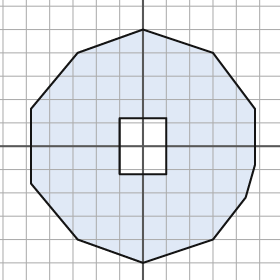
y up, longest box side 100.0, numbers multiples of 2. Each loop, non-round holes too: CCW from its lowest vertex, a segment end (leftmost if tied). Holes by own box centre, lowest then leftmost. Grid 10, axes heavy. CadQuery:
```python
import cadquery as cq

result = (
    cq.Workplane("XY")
    .moveTo(0.0, -50.0)
    .lineTo(30.0, -40.0)
    .lineTo(44.0, -22.0)
    .lineTo(48.0, -8.0)
    .lineTo(48.0, 16.0)
    .lineTo(30.0, 40.0)
    .lineTo(0.0, 50.0)
    .lineTo(-28.0, 40.0)
    .lineTo(-48.0, 16.0)
    .lineTo(-48.0, -16.0)
    .lineTo(-28.0, -40.0)
    .close()
    .moveTo(-10.0, -12.0)
    .lineTo(10.0, -12.0)
    .lineTo(10.0, 12.0)
    .lineTo(-10.0, 12.0)
    .close()
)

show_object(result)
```